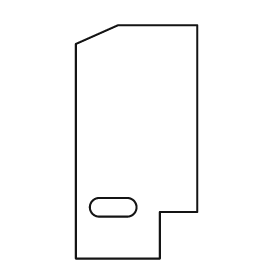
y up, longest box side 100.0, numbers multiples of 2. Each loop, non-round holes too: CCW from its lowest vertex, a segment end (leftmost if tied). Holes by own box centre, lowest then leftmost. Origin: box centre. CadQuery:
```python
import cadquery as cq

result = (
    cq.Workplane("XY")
    .moveTo(-26.0, -50.0)
    .lineTo(10.0, -50.0)
    .lineTo(10.0, -30.0)
    .lineTo(26.0, -30.0)
    .lineTo(26.0, 50.0)
    .lineTo(-8.0, 50.0)
    .lineTo(-26.0, 42.0)
    .close()
    .moveTo(-16.0, -32.0)
    .lineTo(-4.0, -32.0)
    .threePointArc((0.0, -28.0), (-4.0, -24.0))
    .lineTo(-16.0, -24.0)
    .threePointArc((-20.0, -28.0), (-16.0, -32.0))
    .close()
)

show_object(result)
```